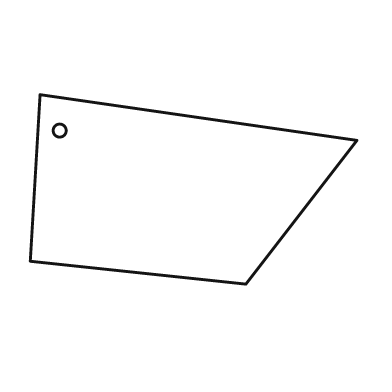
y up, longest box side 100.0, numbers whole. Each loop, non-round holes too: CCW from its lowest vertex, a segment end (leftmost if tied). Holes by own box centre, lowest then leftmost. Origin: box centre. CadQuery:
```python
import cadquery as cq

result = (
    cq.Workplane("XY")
    .moveTo(16.0, -29.0)
    .lineTo(50.0, 15.0)
    .lineTo(-47.0, 29.0)
    .lineTo(-50.0, -22.0)
    .close()
    .moveTo(-41.0, 18.0)
    .circle(2.0)
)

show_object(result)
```